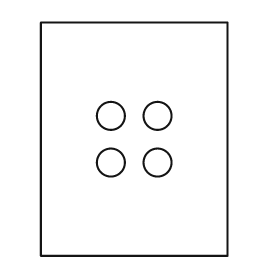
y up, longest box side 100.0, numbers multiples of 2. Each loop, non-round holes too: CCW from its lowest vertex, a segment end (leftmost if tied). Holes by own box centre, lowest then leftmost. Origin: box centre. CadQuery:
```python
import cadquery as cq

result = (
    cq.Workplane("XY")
    .moveTo(-40.0, -50.0)
    .lineTo(40.0, -50.0)
    .lineTo(40.0, 50.0)
    .lineTo(-40.0, 50.0)
    .close()
    .moveTo(-10.0, -10.0)
    .circle(6.0)
    .moveTo(10.0, -10.0)
    .circle(6.0)
    .moveTo(-10.0, 10.0)
    .circle(6.0)
    .moveTo(10.0, 10.0)
    .circle(6.0)
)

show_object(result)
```